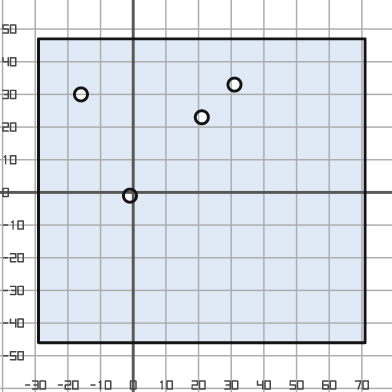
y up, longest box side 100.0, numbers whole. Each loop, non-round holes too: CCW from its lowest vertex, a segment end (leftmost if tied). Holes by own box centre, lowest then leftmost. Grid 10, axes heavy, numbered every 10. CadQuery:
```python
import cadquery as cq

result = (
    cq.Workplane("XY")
    .moveTo(-29.0, -46.0)
    .lineTo(71.0, -46.0)
    .lineTo(71.0, 47.0)
    .lineTo(-29.0, 47.0)
    .close()
    .moveTo(-1.0, -1.0)
    .circle(2.0)
    .moveTo(21.0, 23.0)
    .circle(2.0)
    .moveTo(-16.0, 30.0)
    .circle(2.0)
    .moveTo(31.0, 33.0)
    .circle(2.0)
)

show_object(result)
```